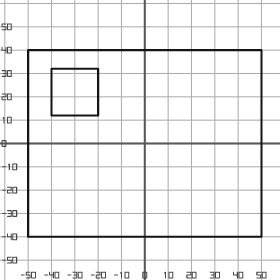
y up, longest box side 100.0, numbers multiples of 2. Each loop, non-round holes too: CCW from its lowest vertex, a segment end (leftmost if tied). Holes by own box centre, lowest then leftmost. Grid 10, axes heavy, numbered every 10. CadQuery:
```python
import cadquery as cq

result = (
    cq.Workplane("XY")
    .moveTo(-50.0, -40.0)
    .lineTo(50.0, -40.0)
    .lineTo(50.0, 40.0)
    .lineTo(-50.0, 40.0)
    .close()
    .moveTo(-40.0, 12.0)
    .lineTo(-20.0, 12.0)
    .lineTo(-20.0, 32.0)
    .lineTo(-40.0, 32.0)
    .close()
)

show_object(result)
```